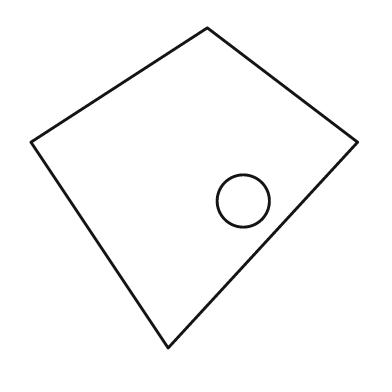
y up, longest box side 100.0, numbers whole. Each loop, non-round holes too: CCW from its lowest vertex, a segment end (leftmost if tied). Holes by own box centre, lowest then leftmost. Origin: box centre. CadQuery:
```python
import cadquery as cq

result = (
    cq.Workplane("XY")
    .moveTo(-8.0, -49.0)
    .lineTo(50.0, 14.0)
    .lineTo(4.0, 49.0)
    .lineTo(-50.0, 14.0)
    .close()
    .moveTo(15.0, -4.0)
    .circle(8.0)
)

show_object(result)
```